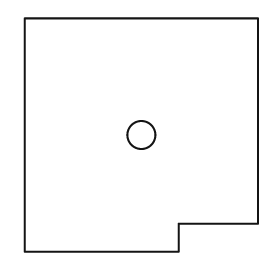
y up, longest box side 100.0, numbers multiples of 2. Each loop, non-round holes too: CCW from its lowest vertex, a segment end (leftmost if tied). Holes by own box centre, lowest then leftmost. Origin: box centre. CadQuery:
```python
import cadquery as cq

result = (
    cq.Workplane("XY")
    .moveTo(-50.0, -50.0)
    .lineTo(16.0, -50.0)
    .lineTo(16.0, -38.0)
    .lineTo(50.0, -38.0)
    .lineTo(50.0, 50.0)
    .lineTo(-50.0, 50.0)
    .close()
    .moveTo(0.0, 0.0)
    .circle(6.0)
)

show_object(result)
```